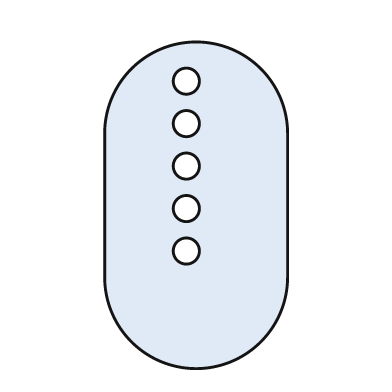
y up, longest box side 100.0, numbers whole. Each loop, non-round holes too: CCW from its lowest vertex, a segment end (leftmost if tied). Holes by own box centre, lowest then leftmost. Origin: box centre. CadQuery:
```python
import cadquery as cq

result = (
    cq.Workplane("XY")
    .moveTo(-28.0, -22.0)
    .threePointArc((0.0, -50.0), (28.0, -22.0))
    .lineTo(28.0, 22.0)
    .threePointArc((0.0, 50.0), (-28.0, 22.0))
    .close()
    .moveTo(-3.0, -14.0)
    .circle(4.0)
    .moveTo(-3.0, -1.0)
    .circle(4.0)
    .moveTo(-3.0, 12.0)
    .circle(4.0)
    .moveTo(-3.0, 25.0)
    .circle(4.0)
    .moveTo(-3.0, 38.0)
    .circle(4.0)
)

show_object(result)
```